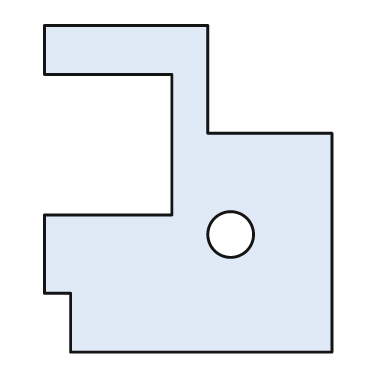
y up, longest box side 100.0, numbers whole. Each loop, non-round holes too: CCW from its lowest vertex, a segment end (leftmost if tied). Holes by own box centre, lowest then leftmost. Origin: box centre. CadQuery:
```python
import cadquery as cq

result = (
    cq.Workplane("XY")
    .moveTo(-36.0, -50.0)
    .lineTo(44.0, -50.0)
    .lineTo(44.0, 17.0)
    .lineTo(6.0, 17.0)
    .lineTo(6.0, 50.0)
    .lineTo(-44.0, 50.0)
    .lineTo(-44.0, 35.0)
    .lineTo(-5.0, 35.0)
    .lineTo(-5.0, -8.0)
    .lineTo(-44.0, -8.0)
    .lineTo(-44.0, -32.0)
    .lineTo(-36.0, -32.0)
    .close()
    .moveTo(13.0, -14.0)
    .circle(7.0)
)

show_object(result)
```